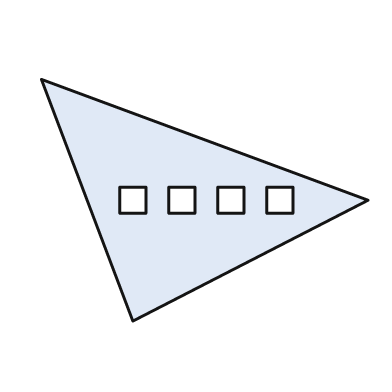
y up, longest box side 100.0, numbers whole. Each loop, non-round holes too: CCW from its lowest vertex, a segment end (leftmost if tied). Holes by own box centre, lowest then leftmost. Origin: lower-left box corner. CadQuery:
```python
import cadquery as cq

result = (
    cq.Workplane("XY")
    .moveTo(28.0, 0.0)
    .lineTo(100.0, 37.0)
    .lineTo(0.0, 74.0)
    .close()
    .moveTo(24.0, 33.0)
    .lineTo(32.0, 33.0)
    .lineTo(32.0, 41.0)
    .lineTo(24.0, 41.0)
    .close()
    .moveTo(39.0, 33.0)
    .lineTo(47.0, 33.0)
    .lineTo(47.0, 41.0)
    .lineTo(39.0, 41.0)
    .close()
    .moveTo(54.0, 33.0)
    .lineTo(62.0, 33.0)
    .lineTo(62.0, 41.0)
    .lineTo(54.0, 41.0)
    .close()
    .moveTo(69.0, 33.0)
    .lineTo(77.0, 33.0)
    .lineTo(77.0, 41.0)
    .lineTo(69.0, 41.0)
    .close()
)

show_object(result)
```